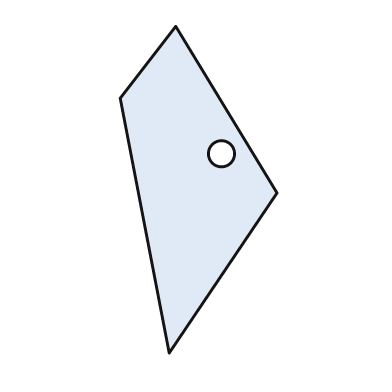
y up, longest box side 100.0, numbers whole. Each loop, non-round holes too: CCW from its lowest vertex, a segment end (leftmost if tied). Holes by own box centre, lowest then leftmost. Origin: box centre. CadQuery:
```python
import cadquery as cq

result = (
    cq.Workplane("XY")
    .moveTo(-9.0, -50.0)
    .lineTo(24.0, -1.0)
    .lineTo(-7.0, 50.0)
    .lineTo(-24.0, 28.0)
    .close()
    .moveTo(7.0, 11.0)
    .circle(4.0)
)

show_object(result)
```